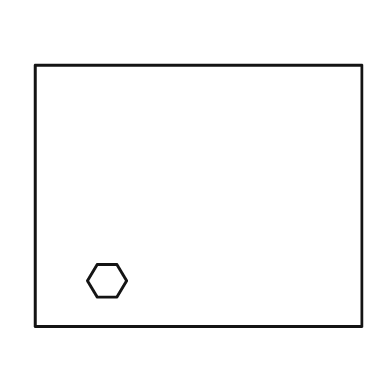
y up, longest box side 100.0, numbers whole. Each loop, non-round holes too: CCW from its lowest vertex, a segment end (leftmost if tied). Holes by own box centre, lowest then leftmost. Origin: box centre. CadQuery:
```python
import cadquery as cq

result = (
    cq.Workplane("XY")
    .moveTo(-50.0, -40.0)
    .lineTo(50.0, -40.0)
    .lineTo(50.0, 40.0)
    .lineTo(-50.0, 40.0)
    .close()
    .moveTo(-31.0, -31.0)
    .lineTo(-25.0, -31.0)
    .lineTo(-22.0, -26.0)
    .lineTo(-25.0, -21.0)
    .lineTo(-31.0, -21.0)
    .lineTo(-34.0, -26.0)
    .close()
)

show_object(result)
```